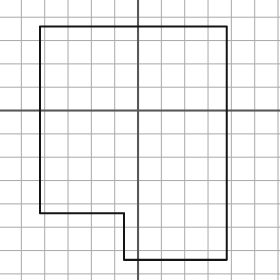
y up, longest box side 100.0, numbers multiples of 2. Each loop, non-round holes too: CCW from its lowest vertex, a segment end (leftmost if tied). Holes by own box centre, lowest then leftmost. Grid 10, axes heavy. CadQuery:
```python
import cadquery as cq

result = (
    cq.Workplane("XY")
    .moveTo(-6.0, -64.0)
    .lineTo(38.0, -64.0)
    .lineTo(38.0, 36.0)
    .lineTo(-42.0, 36.0)
    .lineTo(-42.0, -44.0)
    .lineTo(-6.0, -44.0)
    .close()
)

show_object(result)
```